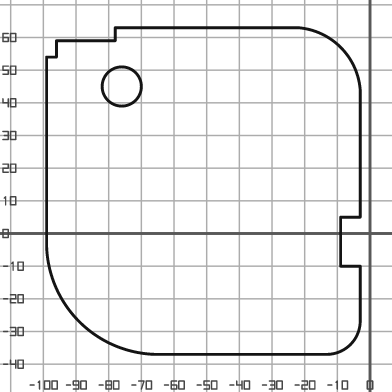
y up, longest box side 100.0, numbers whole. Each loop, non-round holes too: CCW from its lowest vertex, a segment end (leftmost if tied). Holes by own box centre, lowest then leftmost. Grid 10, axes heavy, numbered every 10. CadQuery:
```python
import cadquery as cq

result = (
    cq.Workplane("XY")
    .moveTo(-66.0, -37.0)
    .lineTo(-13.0, -37.0)
    .threePointArc((-6.0, -34.0), (-3.0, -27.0))
    .lineTo(-3.0, -10.0)
    .lineTo(-9.0, -10.0)
    .lineTo(-9.0, 5.0)
    .lineTo(-3.0, 5.0)
    .lineTo(-3.0, 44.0)
    .threePointArc((-9.0, 57.0), (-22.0, 63.0))
    .lineTo(-78.0, 63.0)
    .lineTo(-78.0, 59.0)
    .lineTo(-96.0, 59.0)
    .lineTo(-96.0, 54.0)
    .lineTo(-99.0, 54.0)
    .lineTo(-99.0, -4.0)
    .threePointArc((-89.0, -27.0), (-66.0, -37.0))
    .close()
    .moveTo(-76.0, 45.0)
    .circle(6.0)
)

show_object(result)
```